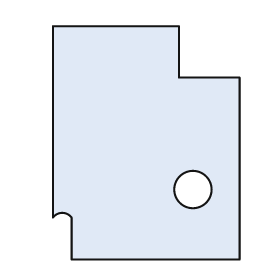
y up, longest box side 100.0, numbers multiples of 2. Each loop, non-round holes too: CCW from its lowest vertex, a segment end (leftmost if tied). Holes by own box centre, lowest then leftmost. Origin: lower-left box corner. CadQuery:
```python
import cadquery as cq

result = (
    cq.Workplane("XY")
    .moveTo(8.0, 0.0)
    .lineTo(80.0, 0.0)
    .lineTo(80.0, 78.0)
    .lineTo(54.0, 78.0)
    .lineTo(54.0, 100.0)
    .lineTo(0.0, 100.0)
    .lineTo(0.0, 18.0)
    .threePointArc((4.0, 20.0), (8.0, 18.0))
    .close()
    .moveTo(60.0, 30.0)
    .circle(8.0)
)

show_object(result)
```